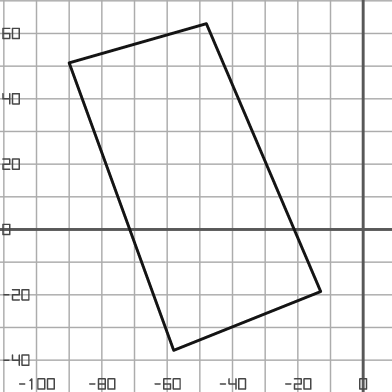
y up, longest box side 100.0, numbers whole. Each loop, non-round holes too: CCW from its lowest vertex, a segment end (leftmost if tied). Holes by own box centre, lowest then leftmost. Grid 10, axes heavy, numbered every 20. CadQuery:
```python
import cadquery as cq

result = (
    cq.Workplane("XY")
    .moveTo(-58.0, -37.0)
    .lineTo(-13.0, -19.0)
    .lineTo(-48.0, 63.0)
    .lineTo(-90.0, 51.0)
    .close()
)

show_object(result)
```